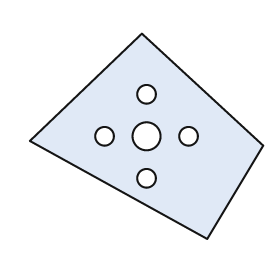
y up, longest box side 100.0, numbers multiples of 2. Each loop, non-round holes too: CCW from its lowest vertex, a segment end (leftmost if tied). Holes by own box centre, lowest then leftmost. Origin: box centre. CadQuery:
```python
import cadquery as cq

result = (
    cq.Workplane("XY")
    .moveTo(26.0, -44.0)
    .lineTo(50.0, -4.0)
    .lineTo(-2.0, 44.0)
    .lineTo(-50.0, -2.0)
    .close()
    .moveTo(0.0, -18.0)
    .circle(4.0)
    .moveTo(-18.0, 0.0)
    .circle(4.0)
    .moveTo(0.0, 0.0)
    .circle(6.0)
    .moveTo(18.0, 0.0)
    .circle(4.0)
    .moveTo(0.0, 18.0)
    .circle(4.0)
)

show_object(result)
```